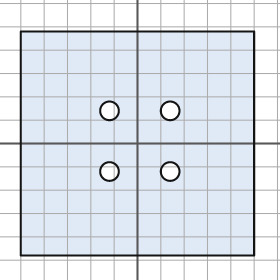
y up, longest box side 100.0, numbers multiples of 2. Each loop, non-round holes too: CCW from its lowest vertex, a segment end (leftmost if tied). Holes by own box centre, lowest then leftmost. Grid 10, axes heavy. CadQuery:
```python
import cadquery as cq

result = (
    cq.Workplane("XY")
    .moveTo(-50.0, -48.0)
    .lineTo(50.0, -48.0)
    .lineTo(50.0, 48.0)
    .lineTo(-50.0, 48.0)
    .close()
    .moveTo(-12.0, -12.0)
    .circle(4.0)
    .moveTo(14.0, -12.0)
    .circle(4.0)
    .moveTo(-12.0, 14.0)
    .circle(4.0)
    .moveTo(14.0, 14.0)
    .circle(4.0)
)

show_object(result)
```